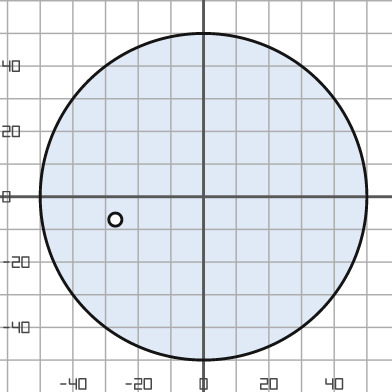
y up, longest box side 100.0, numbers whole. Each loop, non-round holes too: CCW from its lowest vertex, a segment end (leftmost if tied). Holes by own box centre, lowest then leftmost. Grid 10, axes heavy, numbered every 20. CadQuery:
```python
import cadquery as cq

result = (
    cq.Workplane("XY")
    .moveTo(0.0, 0.0)
    .circle(50.0)
    .moveTo(-27.0, -7.0)
    .circle(2.0)
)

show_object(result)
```